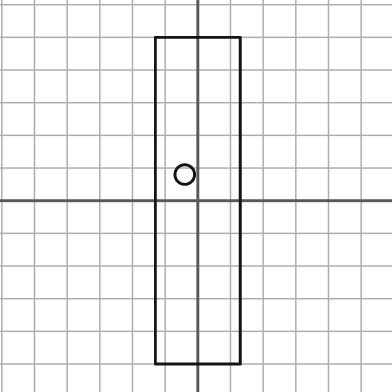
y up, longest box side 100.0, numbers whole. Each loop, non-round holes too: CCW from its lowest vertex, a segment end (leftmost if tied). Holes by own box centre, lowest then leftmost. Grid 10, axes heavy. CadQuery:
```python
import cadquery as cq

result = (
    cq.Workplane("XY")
    .moveTo(-13.0, -50.0)
    .lineTo(13.0, -50.0)
    .lineTo(13.0, 50.0)
    .lineTo(-13.0, 50.0)
    .close()
    .moveTo(-4.0, 8.0)
    .circle(3.0)
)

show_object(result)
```